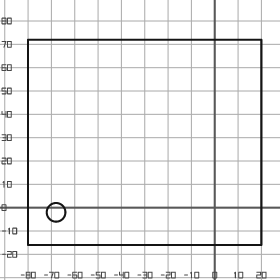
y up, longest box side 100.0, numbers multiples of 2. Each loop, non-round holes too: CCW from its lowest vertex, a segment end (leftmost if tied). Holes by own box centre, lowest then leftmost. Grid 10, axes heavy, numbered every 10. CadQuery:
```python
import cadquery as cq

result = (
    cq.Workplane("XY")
    .moveTo(-80.0, -16.0)
    .lineTo(20.0, -16.0)
    .lineTo(20.0, 72.0)
    .lineTo(-80.0, 72.0)
    .close()
    .moveTo(-68.0, -2.0)
    .circle(4.0)
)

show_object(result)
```